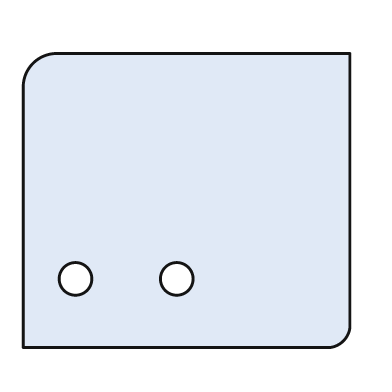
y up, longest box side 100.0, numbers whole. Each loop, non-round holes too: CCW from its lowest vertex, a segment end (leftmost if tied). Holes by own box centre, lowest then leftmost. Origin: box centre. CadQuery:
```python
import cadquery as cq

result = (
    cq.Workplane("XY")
    .moveTo(-50.0, -45.0)
    .lineTo(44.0, -45.0)
    .threePointArc((48.0, -43.0), (50.0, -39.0))
    .lineTo(50.0, 45.0)
    .lineTo(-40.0, 45.0)
    .threePointArc((-47.0, 42.0), (-50.0, 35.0))
    .close()
    .moveTo(-34.0, -24.0)
    .circle(5.0)
    .moveTo(-3.0, -24.0)
    .circle(5.0)
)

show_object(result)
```